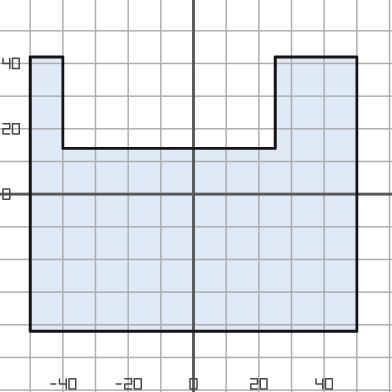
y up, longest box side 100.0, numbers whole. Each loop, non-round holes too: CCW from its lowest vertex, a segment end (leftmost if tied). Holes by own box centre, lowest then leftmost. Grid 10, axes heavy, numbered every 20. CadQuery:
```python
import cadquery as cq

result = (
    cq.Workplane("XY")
    .moveTo(-50.0, -42.0)
    .lineTo(50.0, -42.0)
    .lineTo(50.0, 42.0)
    .lineTo(25.0, 42.0)
    .lineTo(25.0, 14.0)
    .lineTo(-40.0, 14.0)
    .lineTo(-40.0, 42.0)
    .lineTo(-50.0, 42.0)
    .close()
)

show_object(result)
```